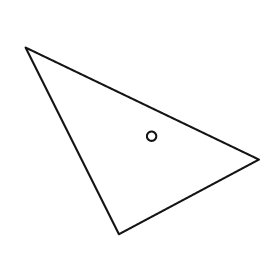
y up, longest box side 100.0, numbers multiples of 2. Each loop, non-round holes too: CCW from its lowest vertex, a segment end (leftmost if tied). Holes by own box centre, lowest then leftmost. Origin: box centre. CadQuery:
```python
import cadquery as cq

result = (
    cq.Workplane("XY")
    .moveTo(-10.0, -40.0)
    .lineTo(50.0, -8.0)
    .lineTo(-50.0, 40.0)
    .close()
    .moveTo(4.0, 2.0)
    .circle(2.0)
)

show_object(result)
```